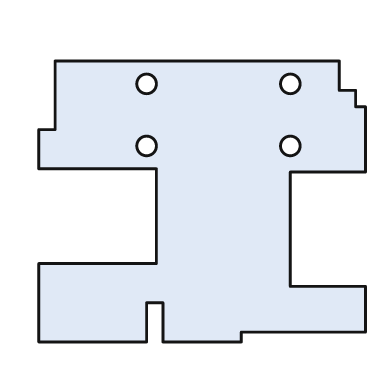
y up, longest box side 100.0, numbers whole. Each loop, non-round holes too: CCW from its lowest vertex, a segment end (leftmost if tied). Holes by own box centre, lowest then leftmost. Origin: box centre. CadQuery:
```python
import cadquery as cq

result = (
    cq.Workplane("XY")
    .moveTo(-50.0, -43.0)
    .lineTo(-17.0, -43.0)
    .lineTo(-17.0, -31.0)
    .lineTo(-12.0, -31.0)
    .lineTo(-12.0, -43.0)
    .lineTo(12.0, -43.0)
    .lineTo(12.0, -40.0)
    .lineTo(50.0, -40.0)
    .lineTo(50.0, -26.0)
    .lineTo(27.0, -26.0)
    .lineTo(27.0, 9.0)
    .lineTo(50.0, 9.0)
    .lineTo(50.0, 29.0)
    .lineTo(47.0, 29.0)
    .lineTo(47.0, 34.0)
    .lineTo(42.0, 34.0)
    .lineTo(42.0, 43.0)
    .lineTo(-45.0, 43.0)
    .lineTo(-45.0, 22.0)
    .lineTo(-50.0, 22.0)
    .lineTo(-50.0, 10.0)
    .lineTo(-14.0, 10.0)
    .lineTo(-14.0, -19.0)
    .lineTo(-50.0, -19.0)
    .close()
    .moveTo(-17.0, 17.0)
    .circle(3.0)
    .moveTo(27.0, 17.0)
    .circle(3.0)
    .moveTo(-17.0, 36.0)
    .circle(3.0)
    .moveTo(27.0, 36.0)
    .circle(3.0)
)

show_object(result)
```